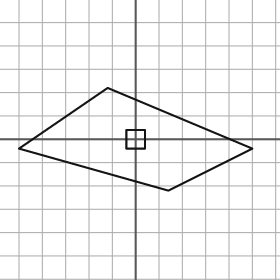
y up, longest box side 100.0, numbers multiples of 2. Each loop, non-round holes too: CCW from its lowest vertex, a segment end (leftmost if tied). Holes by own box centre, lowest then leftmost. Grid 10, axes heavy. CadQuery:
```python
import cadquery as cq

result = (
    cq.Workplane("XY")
    .moveTo(14.0, -22.0)
    .lineTo(50.0, -4.0)
    .lineTo(-12.0, 22.0)
    .lineTo(-50.0, -4.0)
    .close()
    .moveTo(-4.0, -4.0)
    .lineTo(4.0, -4.0)
    .lineTo(4.0, 4.0)
    .lineTo(-4.0, 4.0)
    .close()
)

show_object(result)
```